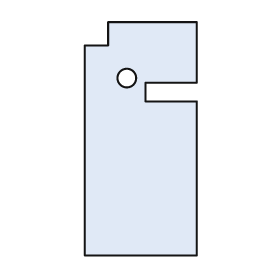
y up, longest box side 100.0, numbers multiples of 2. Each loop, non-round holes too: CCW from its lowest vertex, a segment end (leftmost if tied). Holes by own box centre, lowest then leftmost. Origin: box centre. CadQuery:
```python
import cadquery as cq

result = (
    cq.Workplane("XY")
    .moveTo(-24.0, -50.0)
    .lineTo(24.0, -50.0)
    .lineTo(24.0, 16.0)
    .lineTo(2.0, 16.0)
    .lineTo(2.0, 24.0)
    .lineTo(24.0, 24.0)
    .lineTo(24.0, 50.0)
    .lineTo(-14.0, 50.0)
    .lineTo(-14.0, 40.0)
    .lineTo(-24.0, 40.0)
    .close()
    .moveTo(-6.0, 26.0)
    .circle(4.0)
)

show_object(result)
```